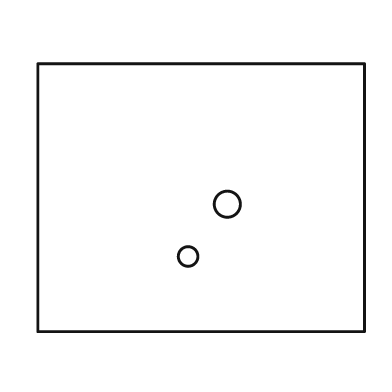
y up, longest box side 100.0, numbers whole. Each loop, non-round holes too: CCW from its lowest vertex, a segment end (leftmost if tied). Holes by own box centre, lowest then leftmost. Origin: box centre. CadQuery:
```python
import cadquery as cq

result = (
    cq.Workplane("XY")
    .moveTo(-50.0, -41.0)
    .lineTo(50.0, -41.0)
    .lineTo(50.0, 41.0)
    .lineTo(-50.0, 41.0)
    .close()
    .moveTo(-4.0, -18.0)
    .circle(3.0)
    .moveTo(8.0, -2.0)
    .circle(4.0)
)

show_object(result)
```